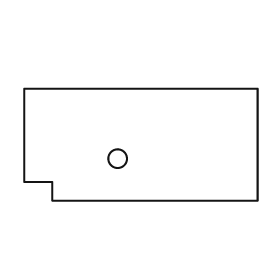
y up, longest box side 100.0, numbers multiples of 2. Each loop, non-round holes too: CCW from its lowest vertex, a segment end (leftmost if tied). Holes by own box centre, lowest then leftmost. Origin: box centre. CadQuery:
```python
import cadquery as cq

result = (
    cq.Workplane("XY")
    .moveTo(-38.0, -24.0)
    .lineTo(50.0, -24.0)
    .lineTo(50.0, 24.0)
    .lineTo(-50.0, 24.0)
    .lineTo(-50.0, -16.0)
    .lineTo(-38.0, -16.0)
    .close()
    .moveTo(-10.0, -6.0)
    .circle(4.0)
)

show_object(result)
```